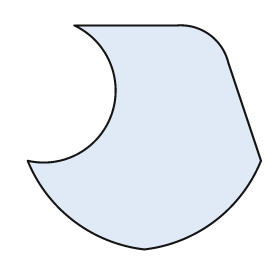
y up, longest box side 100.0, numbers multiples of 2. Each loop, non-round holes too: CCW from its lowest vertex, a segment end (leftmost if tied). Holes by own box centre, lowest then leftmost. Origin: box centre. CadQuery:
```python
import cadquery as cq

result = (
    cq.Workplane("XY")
    .moveTo(0.0, -48.0)
    .threePointArc((30.0, -36.0), (50.0, -10.0))
    .lineTo(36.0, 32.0)
    .threePointArc((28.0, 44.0), (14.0, 48.0))
    .lineTo(-30.0, 48.0)
    .threePointArc((-14.0, 10.0), (-50.0, -10.0))
    .threePointArc((-30.0, -36.0), (0.0, -48.0))
    .close()
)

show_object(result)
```